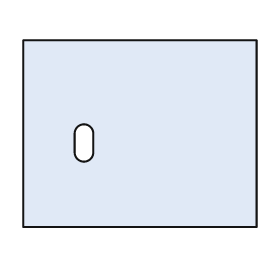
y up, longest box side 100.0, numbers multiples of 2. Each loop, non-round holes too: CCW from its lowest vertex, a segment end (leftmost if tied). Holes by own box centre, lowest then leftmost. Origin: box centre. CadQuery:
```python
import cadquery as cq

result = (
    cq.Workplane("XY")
    .moveTo(-50.0, -40.0)
    .lineTo(50.0, -40.0)
    .lineTo(50.0, 40.0)
    .lineTo(-50.0, 40.0)
    .close()
    .moveTo(-28.0, -8.0)
    .threePointArc((-24.0, -12.0), (-20.0, -8.0))
    .lineTo(-20.0, 0.0)
    .threePointArc((-24.0, 4.0), (-28.0, 0.0))
    .close()
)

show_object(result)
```